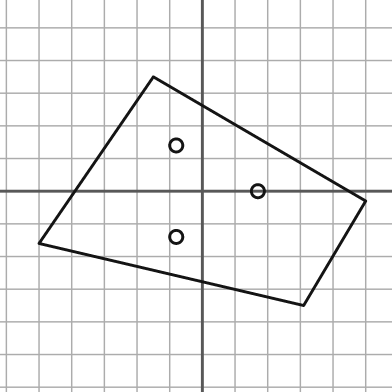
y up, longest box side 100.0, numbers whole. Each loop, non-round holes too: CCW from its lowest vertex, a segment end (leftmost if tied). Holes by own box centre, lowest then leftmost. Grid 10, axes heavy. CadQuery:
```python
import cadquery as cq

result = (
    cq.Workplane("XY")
    .moveTo(31.0, -35.0)
    .lineTo(50.0, -3.0)
    .lineTo(-15.0, 35.0)
    .lineTo(-50.0, -16.0)
    .close()
    .moveTo(-8.0, -14.0)
    .circle(2.0)
    .moveTo(17.0, 0.0)
    .circle(2.0)
    .moveTo(-8.0, 14.0)
    .circle(2.0)
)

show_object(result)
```